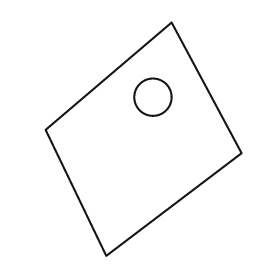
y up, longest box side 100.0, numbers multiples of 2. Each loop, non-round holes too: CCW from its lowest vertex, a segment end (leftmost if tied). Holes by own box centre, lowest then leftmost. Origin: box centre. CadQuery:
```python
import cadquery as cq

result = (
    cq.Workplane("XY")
    .moveTo(-16.0, -50.0)
    .lineTo(42.0, -6.0)
    .lineTo(12.0, 50.0)
    .lineTo(-42.0, 4.0)
    .close()
    .moveTo(4.0, 18.0)
    .circle(8.0)
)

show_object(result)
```